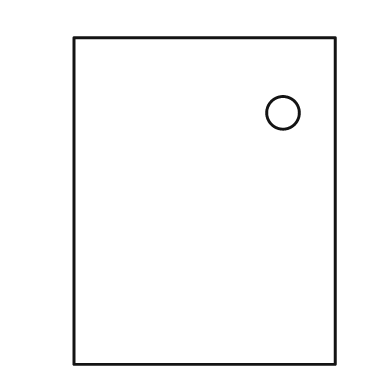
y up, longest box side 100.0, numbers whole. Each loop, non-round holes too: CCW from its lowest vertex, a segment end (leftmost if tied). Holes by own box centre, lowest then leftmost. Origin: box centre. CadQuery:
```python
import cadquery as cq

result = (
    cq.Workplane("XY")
    .moveTo(-40.0, -50.0)
    .lineTo(40.0, -50.0)
    .lineTo(40.0, 50.0)
    .lineTo(-40.0, 50.0)
    .close()
    .moveTo(24.0, 27.0)
    .circle(5.0)
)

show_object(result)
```